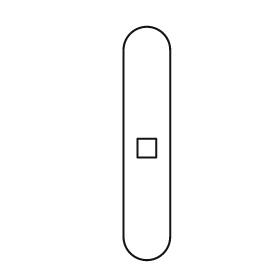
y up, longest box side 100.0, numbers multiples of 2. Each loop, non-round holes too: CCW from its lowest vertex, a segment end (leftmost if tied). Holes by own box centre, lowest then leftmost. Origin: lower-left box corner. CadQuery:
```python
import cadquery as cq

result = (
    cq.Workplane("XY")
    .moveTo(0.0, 10.0)
    .threePointArc((10.0, 0.0), (20.0, 10.0))
    .lineTo(20.0, 90.0)
    .threePointArc((10.0, 100.0), (0.0, 90.0))
    .close()
    .moveTo(6.0, 44.0)
    .lineTo(14.0, 44.0)
    .lineTo(14.0, 52.0)
    .lineTo(6.0, 52.0)
    .close()
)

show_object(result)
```